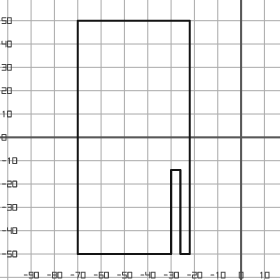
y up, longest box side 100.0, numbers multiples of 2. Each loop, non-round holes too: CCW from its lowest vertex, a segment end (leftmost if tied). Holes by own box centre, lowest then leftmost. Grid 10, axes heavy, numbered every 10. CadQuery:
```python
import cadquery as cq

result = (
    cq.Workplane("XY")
    .moveTo(-70.0, -50.0)
    .lineTo(-30.0, -50.0)
    .lineTo(-30.0, -14.0)
    .lineTo(-26.0, -14.0)
    .lineTo(-26.0, -50.0)
    .lineTo(-22.0, -50.0)
    .lineTo(-22.0, 50.0)
    .lineTo(-70.0, 50.0)
    .close()
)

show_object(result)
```